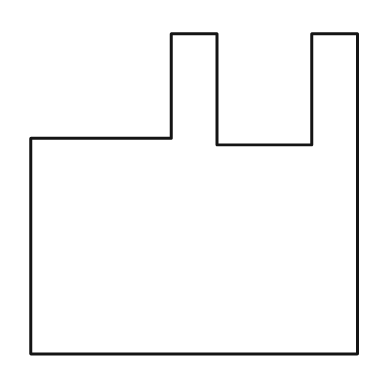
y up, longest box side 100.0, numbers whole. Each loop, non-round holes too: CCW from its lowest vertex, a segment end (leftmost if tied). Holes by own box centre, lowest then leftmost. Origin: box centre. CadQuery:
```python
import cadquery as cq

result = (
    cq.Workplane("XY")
    .moveTo(-50.0, -49.0)
    .lineTo(50.0, -49.0)
    .lineTo(50.0, 49.0)
    .lineTo(36.0, 49.0)
    .lineTo(36.0, 15.0)
    .lineTo(7.0, 15.0)
    .lineTo(7.0, 49.0)
    .lineTo(-7.0, 49.0)
    .lineTo(-7.0, 17.0)
    .lineTo(-50.0, 17.0)
    .close()
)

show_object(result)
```